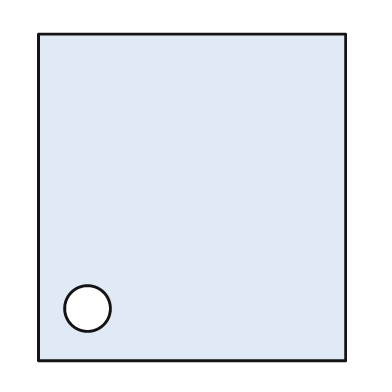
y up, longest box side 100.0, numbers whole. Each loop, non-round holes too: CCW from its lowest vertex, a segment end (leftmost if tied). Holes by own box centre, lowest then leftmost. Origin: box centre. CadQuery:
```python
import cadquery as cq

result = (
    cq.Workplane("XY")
    .moveTo(-47.0, -50.0)
    .lineTo(47.0, -50.0)
    .lineTo(47.0, 50.0)
    .lineTo(-47.0, 50.0)
    .close()
    .moveTo(-32.0, -34.0)
    .circle(7.0)
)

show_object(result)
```